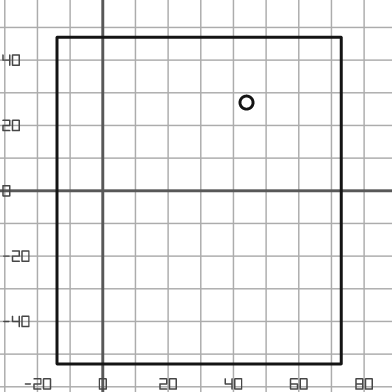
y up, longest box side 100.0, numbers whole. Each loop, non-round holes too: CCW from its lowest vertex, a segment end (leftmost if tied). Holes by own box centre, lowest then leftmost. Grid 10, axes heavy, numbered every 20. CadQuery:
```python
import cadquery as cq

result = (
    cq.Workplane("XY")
    .moveTo(-14.0, -53.0)
    .lineTo(73.0, -53.0)
    .lineTo(73.0, 47.0)
    .lineTo(-14.0, 47.0)
    .close()
    .moveTo(44.0, 27.0)
    .circle(2.0)
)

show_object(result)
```